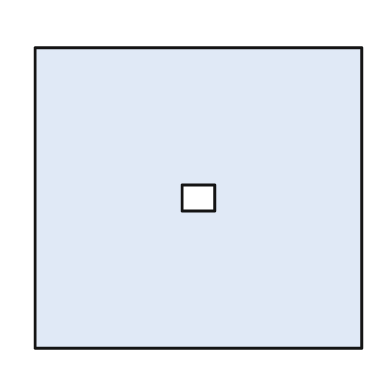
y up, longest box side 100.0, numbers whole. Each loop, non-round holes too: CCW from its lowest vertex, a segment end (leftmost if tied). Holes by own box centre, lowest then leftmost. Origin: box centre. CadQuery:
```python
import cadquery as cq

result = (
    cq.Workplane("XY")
    .moveTo(-50.0, -46.0)
    .lineTo(50.0, -46.0)
    .lineTo(50.0, 46.0)
    .lineTo(-50.0, 46.0)
    .close()
    .moveTo(-5.0, -4.0)
    .lineTo(5.0, -4.0)
    .lineTo(5.0, 4.0)
    .lineTo(-5.0, 4.0)
    .close()
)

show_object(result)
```